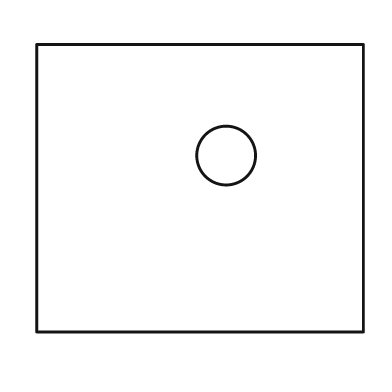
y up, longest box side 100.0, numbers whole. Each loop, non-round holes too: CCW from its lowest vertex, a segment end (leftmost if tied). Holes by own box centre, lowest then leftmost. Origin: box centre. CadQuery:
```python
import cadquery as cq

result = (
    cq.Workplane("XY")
    .moveTo(-50.0, -44.0)
    .lineTo(50.0, -44.0)
    .lineTo(50.0, 44.0)
    .lineTo(-50.0, 44.0)
    .close()
    .moveTo(8.0, 10.0)
    .circle(9.0)
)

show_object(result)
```